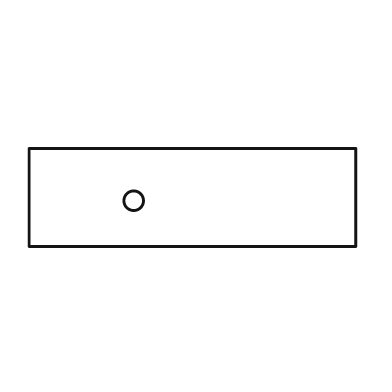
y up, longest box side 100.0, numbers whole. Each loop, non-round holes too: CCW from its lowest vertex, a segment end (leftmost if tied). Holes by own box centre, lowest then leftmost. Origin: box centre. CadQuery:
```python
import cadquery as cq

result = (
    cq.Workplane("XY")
    .moveTo(-50.0, -15.0)
    .lineTo(50.0, -15.0)
    .lineTo(50.0, 15.0)
    .lineTo(-50.0, 15.0)
    .close()
    .moveTo(-18.0, -1.0)
    .circle(3.0)
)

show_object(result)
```